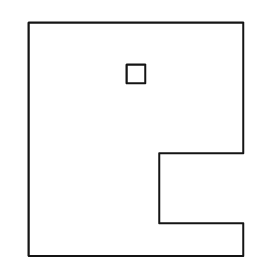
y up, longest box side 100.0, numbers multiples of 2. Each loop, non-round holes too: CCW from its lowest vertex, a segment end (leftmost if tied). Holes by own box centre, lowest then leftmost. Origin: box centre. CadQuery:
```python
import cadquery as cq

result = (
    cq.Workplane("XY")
    .moveTo(-46.0, -50.0)
    .lineTo(46.0, -50.0)
    .lineTo(46.0, -36.0)
    .lineTo(10.0, -36.0)
    .lineTo(10.0, -6.0)
    .lineTo(46.0, -6.0)
    .lineTo(46.0, 50.0)
    .lineTo(-46.0, 50.0)
    .close()
    .moveTo(-4.0, 24.0)
    .lineTo(4.0, 24.0)
    .lineTo(4.0, 32.0)
    .lineTo(-4.0, 32.0)
    .close()
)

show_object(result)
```